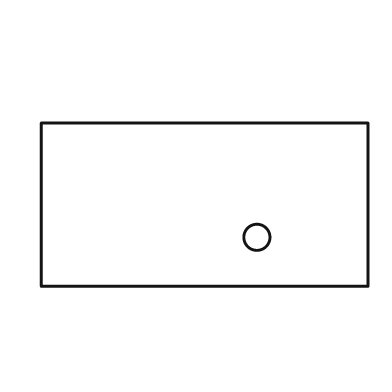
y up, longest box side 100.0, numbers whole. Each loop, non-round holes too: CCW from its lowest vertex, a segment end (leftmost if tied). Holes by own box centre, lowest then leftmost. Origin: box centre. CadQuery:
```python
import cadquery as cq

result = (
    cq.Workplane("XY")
    .moveTo(-50.0, -25.0)
    .lineTo(50.0, -25.0)
    .lineTo(50.0, 25.0)
    .lineTo(-50.0, 25.0)
    .close()
    .moveTo(16.0, -10.0)
    .circle(4.0)
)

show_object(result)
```